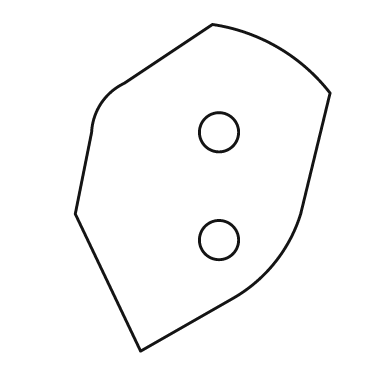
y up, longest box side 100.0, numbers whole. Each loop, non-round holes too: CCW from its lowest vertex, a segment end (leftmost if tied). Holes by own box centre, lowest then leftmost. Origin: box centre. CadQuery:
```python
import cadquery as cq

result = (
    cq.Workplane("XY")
    .moveTo(-19.0, -50.0)
    .lineTo(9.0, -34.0)
    .threePointArc((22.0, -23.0), (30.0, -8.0))
    .lineTo(39.0, 29.0)
    .threePointArc((23.0, 43.0), (3.0, 50.0))
    .lineTo(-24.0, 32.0)
    .threePointArc((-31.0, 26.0), (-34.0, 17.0))
    .lineTo(-39.0, -8.0)
    .close()
    .moveTo(5.0, -16.0)
    .circle(6.0)
    .moveTo(5.0, 17.0)
    .circle(6.0)
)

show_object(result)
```